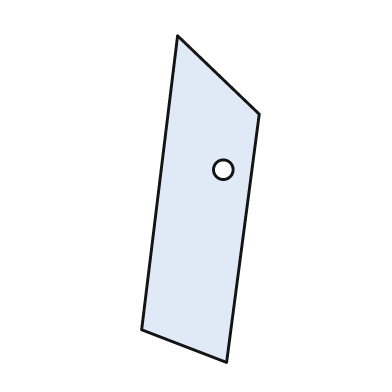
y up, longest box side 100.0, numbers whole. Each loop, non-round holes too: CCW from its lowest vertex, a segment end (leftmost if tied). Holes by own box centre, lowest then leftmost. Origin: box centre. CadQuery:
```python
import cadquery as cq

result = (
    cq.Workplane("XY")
    .moveTo(8.0, -50.0)
    .lineTo(18.0, 26.0)
    .lineTo(-7.0, 50.0)
    .lineTo(-18.0, -40.0)
    .close()
    .moveTo(7.0, 9.0)
    .circle(3.0)
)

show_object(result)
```